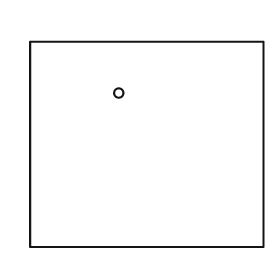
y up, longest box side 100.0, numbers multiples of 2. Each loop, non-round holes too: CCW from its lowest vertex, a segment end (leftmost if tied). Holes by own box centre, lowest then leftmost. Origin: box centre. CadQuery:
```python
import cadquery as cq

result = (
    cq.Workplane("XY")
    .moveTo(-50.0, -44.0)
    .lineTo(50.0, -44.0)
    .lineTo(50.0, 44.0)
    .lineTo(-50.0, 44.0)
    .close()
    .moveTo(-12.0, 22.0)
    .circle(2.0)
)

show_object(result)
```